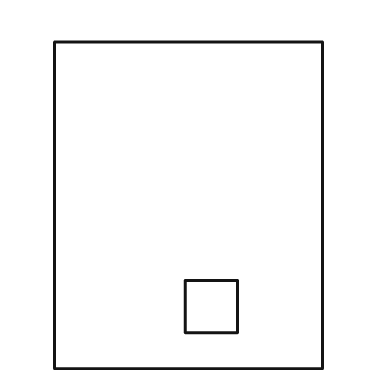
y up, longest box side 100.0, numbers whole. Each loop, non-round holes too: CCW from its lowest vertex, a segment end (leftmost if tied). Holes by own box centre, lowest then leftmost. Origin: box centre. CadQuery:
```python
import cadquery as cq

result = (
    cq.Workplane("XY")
    .moveTo(-41.0, -50.0)
    .lineTo(41.0, -50.0)
    .lineTo(41.0, 50.0)
    .lineTo(-41.0, 50.0)
    .close()
    .moveTo(-1.0, -39.0)
    .lineTo(15.0, -39.0)
    .lineTo(15.0, -23.0)
    .lineTo(-1.0, -23.0)
    .close()
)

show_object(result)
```